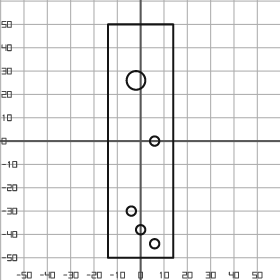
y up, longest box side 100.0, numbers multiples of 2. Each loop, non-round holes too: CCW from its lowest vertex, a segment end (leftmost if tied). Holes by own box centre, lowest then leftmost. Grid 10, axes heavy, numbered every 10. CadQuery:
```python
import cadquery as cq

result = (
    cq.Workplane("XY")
    .moveTo(-14.0, -50.0)
    .lineTo(14.0, -50.0)
    .lineTo(14.0, 50.0)
    .lineTo(-14.0, 50.0)
    .close()
    .moveTo(6.0, -44.0)
    .circle(2.0)
    .moveTo(0.0, -38.0)
    .circle(2.0)
    .moveTo(-4.0, -30.0)
    .circle(2.0)
    .moveTo(6.0, 0.0)
    .circle(2.0)
    .moveTo(-2.0, 26.0)
    .circle(4.0)
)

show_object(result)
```